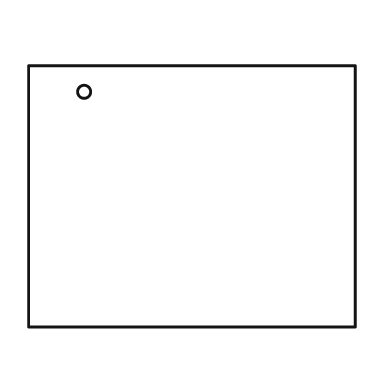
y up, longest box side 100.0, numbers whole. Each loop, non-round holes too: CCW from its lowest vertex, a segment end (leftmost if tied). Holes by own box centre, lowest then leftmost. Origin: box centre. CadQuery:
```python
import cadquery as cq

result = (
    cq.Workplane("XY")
    .moveTo(-50.0, -40.0)
    .lineTo(50.0, -40.0)
    .lineTo(50.0, 40.0)
    .lineTo(-50.0, 40.0)
    .close()
    .moveTo(-33.0, 32.0)
    .circle(2.0)
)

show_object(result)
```